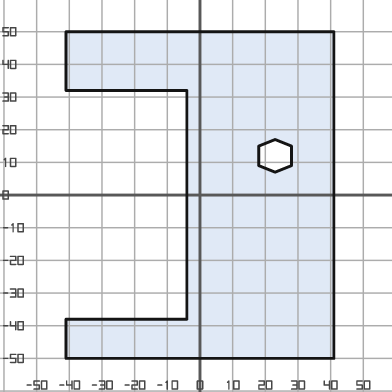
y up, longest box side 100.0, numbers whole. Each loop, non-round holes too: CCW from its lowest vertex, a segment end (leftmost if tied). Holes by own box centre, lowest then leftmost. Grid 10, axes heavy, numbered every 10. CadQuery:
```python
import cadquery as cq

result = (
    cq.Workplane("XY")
    .moveTo(-41.0, -50.0)
    .lineTo(41.0, -50.0)
    .lineTo(41.0, 50.0)
    .lineTo(-41.0, 50.0)
    .lineTo(-41.0, 32.0)
    .lineTo(-4.0, 32.0)
    .lineTo(-4.0, -38.0)
    .lineTo(-41.0, -38.0)
    .close()
    .moveTo(23.0, 7.0)
    .lineTo(28.0, 9.0)
    .lineTo(28.0, 15.0)
    .lineTo(23.0, 17.0)
    .lineTo(18.0, 15.0)
    .lineTo(18.0, 9.0)
    .close()
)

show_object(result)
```